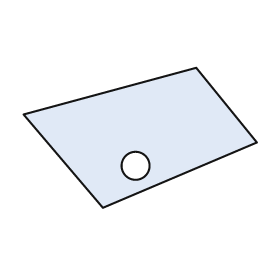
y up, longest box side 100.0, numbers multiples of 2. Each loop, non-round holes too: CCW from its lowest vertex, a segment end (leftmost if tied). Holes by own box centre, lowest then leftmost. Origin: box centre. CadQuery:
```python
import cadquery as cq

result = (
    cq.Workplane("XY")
    .moveTo(-16.0, -30.0)
    .lineTo(50.0, -2.0)
    .lineTo(24.0, 30.0)
    .lineTo(-50.0, 10.0)
    .close()
    .moveTo(-2.0, -12.0)
    .circle(6.0)
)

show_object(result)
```